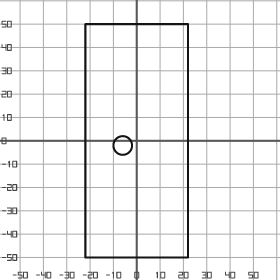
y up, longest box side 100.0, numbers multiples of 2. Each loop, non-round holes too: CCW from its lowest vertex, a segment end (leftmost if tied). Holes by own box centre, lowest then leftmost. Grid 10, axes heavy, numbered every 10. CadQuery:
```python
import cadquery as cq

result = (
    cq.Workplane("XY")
    .moveTo(-22.0, -50.0)
    .lineTo(22.0, -50.0)
    .lineTo(22.0, 50.0)
    .lineTo(-22.0, 50.0)
    .close()
    .moveTo(-6.0, -2.0)
    .circle(4.0)
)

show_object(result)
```